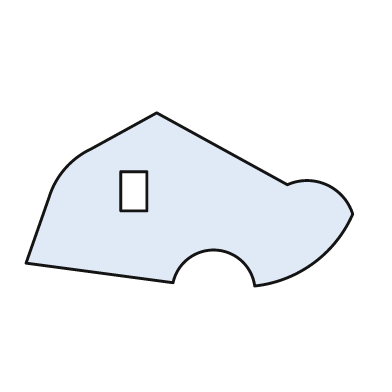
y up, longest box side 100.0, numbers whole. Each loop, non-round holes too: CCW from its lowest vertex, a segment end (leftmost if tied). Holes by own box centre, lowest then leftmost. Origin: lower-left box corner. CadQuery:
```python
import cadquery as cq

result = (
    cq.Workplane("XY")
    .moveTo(70.0, 0.0)
    .threePointArc((88.0, 7.0), (100.0, 22.0))
    .threePointArc((92.0, 31.0), (80.0, 31.0))
    .lineTo(40.0, 53.0)
    .lineTo(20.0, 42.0)
    .threePointArc((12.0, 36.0), (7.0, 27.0))
    .lineTo(0.0, 7.0)
    .lineTo(45.0, 1.0)
    .threePointArc((58.0, 11.0), (70.0, 0.0))
    .close()
    .moveTo(29.0, 23.0)
    .lineTo(37.0, 23.0)
    .lineTo(37.0, 35.0)
    .lineTo(29.0, 35.0)
    .close()
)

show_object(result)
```